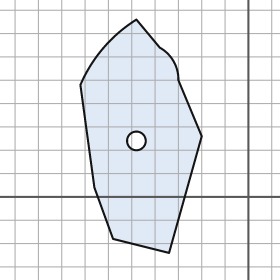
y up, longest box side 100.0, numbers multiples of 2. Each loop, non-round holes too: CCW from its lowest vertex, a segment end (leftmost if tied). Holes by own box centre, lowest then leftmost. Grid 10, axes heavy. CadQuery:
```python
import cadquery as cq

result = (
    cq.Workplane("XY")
    .moveTo(-34.0, -24.0)
    .lineTo(-20.0, 26.0)
    .lineTo(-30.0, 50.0)
    .threePointArc((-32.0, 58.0), (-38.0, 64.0))
    .lineTo(-48.0, 76.0)
    .threePointArc((-62.0, 64.0), (-72.0, 48.0))
    .lineTo(-66.0, 4.0)
    .lineTo(-58.0, -18.0)
    .close()
    .moveTo(-48.0, 24.0)
    .circle(4.0)
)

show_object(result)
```